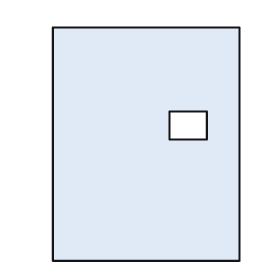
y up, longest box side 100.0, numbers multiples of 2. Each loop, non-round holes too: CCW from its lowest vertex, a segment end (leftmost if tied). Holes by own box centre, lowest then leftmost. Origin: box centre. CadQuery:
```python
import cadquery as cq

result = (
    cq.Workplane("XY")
    .moveTo(-40.0, -50.0)
    .lineTo(40.0, -50.0)
    .lineTo(40.0, 50.0)
    .lineTo(-40.0, 50.0)
    .close()
    .moveTo(10.0, 2.0)
    .lineTo(26.0, 2.0)
    .lineTo(26.0, 14.0)
    .lineTo(10.0, 14.0)
    .close()
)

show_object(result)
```